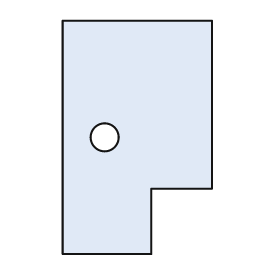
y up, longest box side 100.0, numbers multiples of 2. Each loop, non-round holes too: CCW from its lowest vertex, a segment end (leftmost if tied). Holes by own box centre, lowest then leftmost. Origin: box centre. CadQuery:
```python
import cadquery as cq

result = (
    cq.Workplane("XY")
    .moveTo(-32.0, -50.0)
    .lineTo(6.0, -50.0)
    .lineTo(6.0, -22.0)
    .lineTo(32.0, -22.0)
    .lineTo(32.0, 50.0)
    .lineTo(-32.0, 50.0)
    .close()
    .moveTo(-14.0, 0.0)
    .circle(6.0)
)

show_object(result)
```